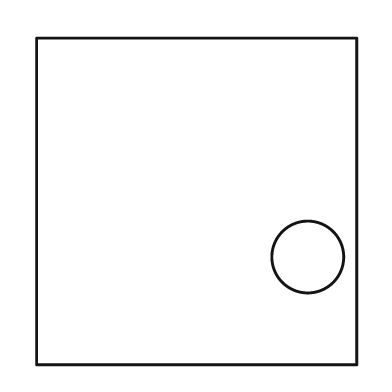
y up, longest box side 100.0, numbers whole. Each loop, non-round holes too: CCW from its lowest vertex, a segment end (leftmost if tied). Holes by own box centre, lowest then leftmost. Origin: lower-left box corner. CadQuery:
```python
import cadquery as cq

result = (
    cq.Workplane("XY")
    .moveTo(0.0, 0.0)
    .lineTo(98.0, 0.0)
    .lineTo(98.0, 100.0)
    .lineTo(0.0, 100.0)
    .close()
    .moveTo(83.0, 33.0)
    .circle(11.0)
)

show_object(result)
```